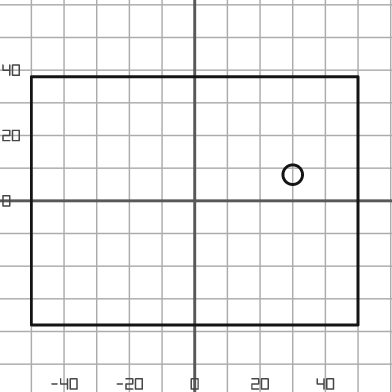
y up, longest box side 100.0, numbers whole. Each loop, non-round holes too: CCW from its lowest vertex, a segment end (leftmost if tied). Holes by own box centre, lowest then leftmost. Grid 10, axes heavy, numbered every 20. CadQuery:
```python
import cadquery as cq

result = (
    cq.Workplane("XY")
    .moveTo(-50.0, -38.0)
    .lineTo(50.0, -38.0)
    .lineTo(50.0, 38.0)
    .lineTo(-50.0, 38.0)
    .close()
    .moveTo(30.0, 8.0)
    .circle(3.0)
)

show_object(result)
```